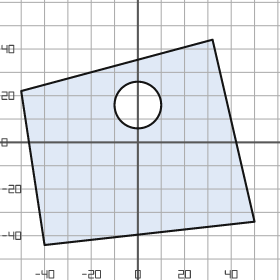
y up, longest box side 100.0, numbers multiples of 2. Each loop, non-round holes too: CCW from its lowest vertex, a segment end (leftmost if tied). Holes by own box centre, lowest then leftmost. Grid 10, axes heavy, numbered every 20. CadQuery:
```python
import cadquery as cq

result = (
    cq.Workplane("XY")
    .moveTo(-40.0, -44.0)
    .lineTo(50.0, -34.0)
    .lineTo(32.0, 44.0)
    .lineTo(-50.0, 22.0)
    .close()
    .moveTo(0.0, 16.0)
    .circle(10.0)
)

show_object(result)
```